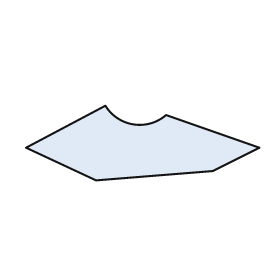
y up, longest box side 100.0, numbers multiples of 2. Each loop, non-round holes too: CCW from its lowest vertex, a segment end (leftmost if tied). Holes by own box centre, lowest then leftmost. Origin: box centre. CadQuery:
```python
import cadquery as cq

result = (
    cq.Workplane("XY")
    .moveTo(-20.0, -16.0)
    .lineTo(30.0, -12.0)
    .lineTo(50.0, -2.0)
    .lineTo(10.0, 12.0)
    .threePointArc((-4.0, 8.0), (-16.0, 16.0))
    .lineTo(-50.0, -2.0)
    .close()
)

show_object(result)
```